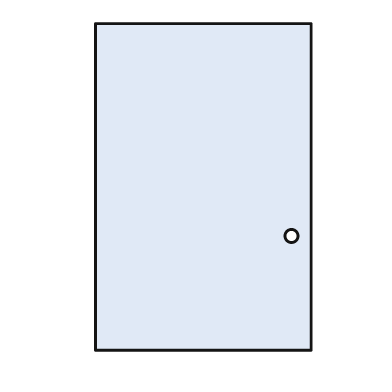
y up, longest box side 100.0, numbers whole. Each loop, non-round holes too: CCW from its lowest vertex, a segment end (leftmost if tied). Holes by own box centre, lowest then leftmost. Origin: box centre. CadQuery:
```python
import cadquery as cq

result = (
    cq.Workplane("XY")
    .moveTo(-33.0, -50.0)
    .lineTo(33.0, -50.0)
    .lineTo(33.0, 50.0)
    .lineTo(-33.0, 50.0)
    .close()
    .moveTo(27.0, -15.0)
    .circle(2.0)
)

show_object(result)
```